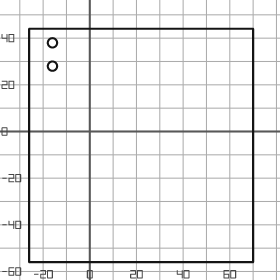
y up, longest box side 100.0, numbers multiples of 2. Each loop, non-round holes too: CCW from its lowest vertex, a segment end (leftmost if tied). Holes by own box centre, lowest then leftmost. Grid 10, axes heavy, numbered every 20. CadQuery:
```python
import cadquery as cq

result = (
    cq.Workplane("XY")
    .moveTo(-26.0, -56.0)
    .lineTo(70.0, -56.0)
    .lineTo(70.0, 44.0)
    .lineTo(-26.0, 44.0)
    .close()
    .moveTo(-16.0, 28.0)
    .circle(2.0)
    .moveTo(-16.0, 38.0)
    .circle(2.0)
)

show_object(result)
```